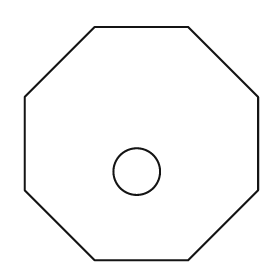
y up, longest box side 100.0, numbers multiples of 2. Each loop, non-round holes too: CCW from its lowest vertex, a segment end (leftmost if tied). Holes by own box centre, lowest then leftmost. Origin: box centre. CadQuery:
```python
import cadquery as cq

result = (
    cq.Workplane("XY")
    .moveTo(-20.0, -50.0)
    .lineTo(20.0, -50.0)
    .lineTo(50.0, -20.0)
    .lineTo(50.0, 20.0)
    .lineTo(20.0, 50.0)
    .lineTo(-20.0, 50.0)
    .lineTo(-50.0, 20.0)
    .lineTo(-50.0, -20.0)
    .close()
    .moveTo(-2.0, -12.0)
    .circle(10.0)
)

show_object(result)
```